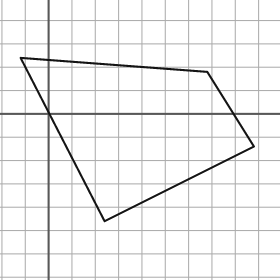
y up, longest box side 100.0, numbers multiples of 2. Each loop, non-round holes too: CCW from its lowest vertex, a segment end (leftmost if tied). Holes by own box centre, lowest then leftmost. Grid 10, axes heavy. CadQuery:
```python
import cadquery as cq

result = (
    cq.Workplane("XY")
    .moveTo(24.0, -46.0)
    .lineTo(88.0, -14.0)
    .lineTo(68.0, 18.0)
    .lineTo(-12.0, 24.0)
    .close()
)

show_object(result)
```